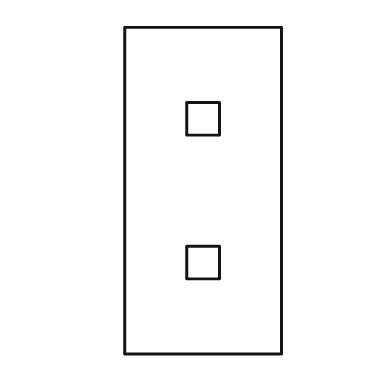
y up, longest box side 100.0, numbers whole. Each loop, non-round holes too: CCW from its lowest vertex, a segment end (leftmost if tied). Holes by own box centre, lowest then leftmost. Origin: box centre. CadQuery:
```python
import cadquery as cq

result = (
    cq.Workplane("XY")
    .moveTo(-24.0, -50.0)
    .lineTo(24.0, -50.0)
    .lineTo(24.0, 50.0)
    .lineTo(-24.0, 50.0)
    .close()
    .moveTo(-5.0, -27.0)
    .lineTo(5.0, -27.0)
    .lineTo(5.0, -17.0)
    .lineTo(-5.0, -17.0)
    .close()
    .moveTo(-5.0, 17.0)
    .lineTo(5.0, 17.0)
    .lineTo(5.0, 27.0)
    .lineTo(-5.0, 27.0)
    .close()
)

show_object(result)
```